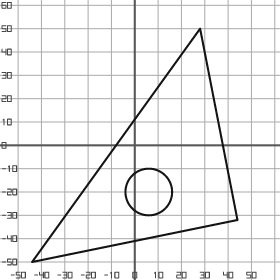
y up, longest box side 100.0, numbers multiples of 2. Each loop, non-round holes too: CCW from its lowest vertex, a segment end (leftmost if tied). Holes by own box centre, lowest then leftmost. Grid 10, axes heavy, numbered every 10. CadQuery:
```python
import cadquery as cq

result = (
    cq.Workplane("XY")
    .moveTo(-44.0, -50.0)
    .lineTo(44.0, -32.0)
    .lineTo(28.0, 50.0)
    .close()
    .moveTo(6.0, -20.0)
    .circle(10.0)
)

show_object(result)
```